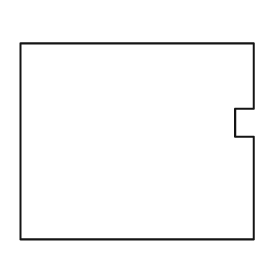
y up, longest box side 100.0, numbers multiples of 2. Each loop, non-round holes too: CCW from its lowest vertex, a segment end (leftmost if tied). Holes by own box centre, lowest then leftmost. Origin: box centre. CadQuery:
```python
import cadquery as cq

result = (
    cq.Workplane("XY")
    .moveTo(-50.0, -42.0)
    .lineTo(50.0, -42.0)
    .lineTo(50.0, 2.0)
    .lineTo(42.0, 2.0)
    .lineTo(42.0, 14.0)
    .lineTo(50.0, 14.0)
    .lineTo(50.0, 42.0)
    .lineTo(-50.0, 42.0)
    .close()
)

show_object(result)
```